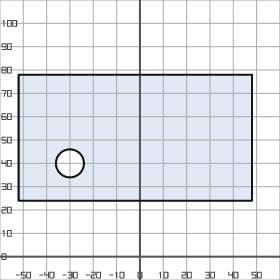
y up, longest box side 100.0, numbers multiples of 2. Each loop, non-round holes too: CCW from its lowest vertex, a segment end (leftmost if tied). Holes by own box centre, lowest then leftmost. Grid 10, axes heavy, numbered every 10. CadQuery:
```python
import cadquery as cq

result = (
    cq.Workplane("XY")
    .moveTo(-52.0, 24.0)
    .lineTo(48.0, 24.0)
    .lineTo(48.0, 78.0)
    .lineTo(-52.0, 78.0)
    .close()
    .moveTo(-30.0, 40.0)
    .circle(6.0)
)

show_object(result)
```